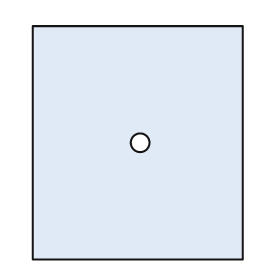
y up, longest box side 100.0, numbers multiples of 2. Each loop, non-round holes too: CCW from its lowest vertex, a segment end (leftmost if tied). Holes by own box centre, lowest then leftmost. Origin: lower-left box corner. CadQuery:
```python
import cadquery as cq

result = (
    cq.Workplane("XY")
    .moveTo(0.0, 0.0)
    .lineTo(90.0, 0.0)
    .lineTo(90.0, 100.0)
    .lineTo(0.0, 100.0)
    .close()
    .moveTo(46.0, 50.0)
    .circle(4.0)
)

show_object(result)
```